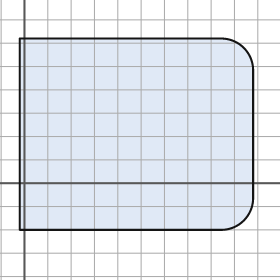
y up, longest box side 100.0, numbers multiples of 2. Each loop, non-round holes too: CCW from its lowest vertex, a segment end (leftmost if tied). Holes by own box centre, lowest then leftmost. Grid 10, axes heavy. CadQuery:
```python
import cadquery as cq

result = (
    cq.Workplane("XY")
    .moveTo(-2.0, -20.0)
    .lineTo(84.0, -20.0)
    .threePointArc((94.0, -16.0), (98.0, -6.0))
    .lineTo(98.0, 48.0)
    .threePointArc((94.0, 58.0), (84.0, 62.0))
    .lineTo(-2.0, 62.0)
    .close()
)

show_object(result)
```